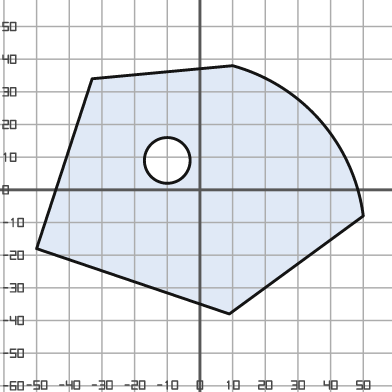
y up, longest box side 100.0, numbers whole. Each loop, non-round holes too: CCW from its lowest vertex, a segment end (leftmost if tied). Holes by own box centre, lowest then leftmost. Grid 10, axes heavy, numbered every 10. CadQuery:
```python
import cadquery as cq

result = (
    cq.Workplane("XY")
    .moveTo(9.0, -38.0)
    .lineTo(50.0, -8.0)
    .threePointArc((37.0, 21.0), (10.0, 38.0))
    .lineTo(-33.0, 34.0)
    .lineTo(-50.0, -18.0)
    .close()
    .moveTo(-10.0, 9.0)
    .circle(7.0)
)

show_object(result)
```